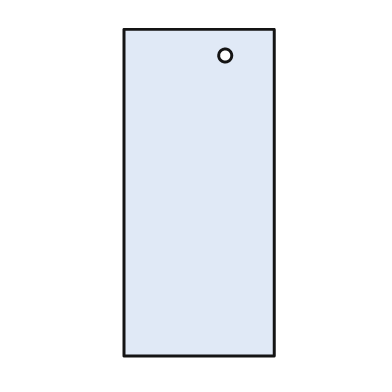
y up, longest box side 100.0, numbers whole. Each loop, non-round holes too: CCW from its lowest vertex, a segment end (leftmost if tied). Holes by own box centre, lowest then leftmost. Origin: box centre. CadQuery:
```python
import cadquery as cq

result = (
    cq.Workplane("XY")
    .moveTo(-23.0, -50.0)
    .lineTo(23.0, -50.0)
    .lineTo(23.0, 50.0)
    .lineTo(-23.0, 50.0)
    .close()
    .moveTo(8.0, 42.0)
    .circle(2.0)
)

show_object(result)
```